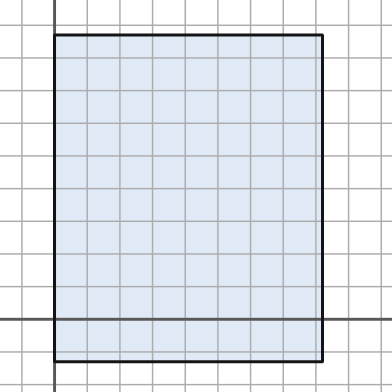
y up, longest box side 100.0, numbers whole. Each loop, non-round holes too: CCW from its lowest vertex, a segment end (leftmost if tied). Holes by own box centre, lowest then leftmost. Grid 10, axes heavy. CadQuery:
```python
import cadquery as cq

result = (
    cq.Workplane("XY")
    .moveTo(0.0, -13.0)
    .lineTo(82.0, -13.0)
    .lineTo(82.0, 87.0)
    .lineTo(0.0, 87.0)
    .close()
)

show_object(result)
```